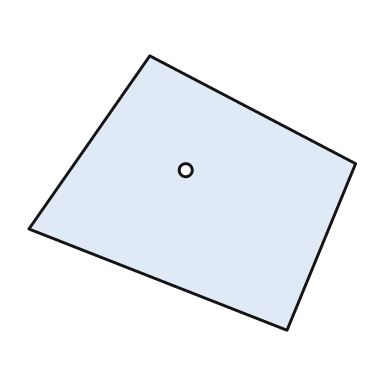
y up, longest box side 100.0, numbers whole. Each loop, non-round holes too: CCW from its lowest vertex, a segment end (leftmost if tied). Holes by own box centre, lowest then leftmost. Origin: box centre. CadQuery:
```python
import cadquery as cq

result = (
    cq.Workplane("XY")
    .moveTo(29.0, -42.0)
    .lineTo(50.0, 9.0)
    .lineTo(-13.0, 42.0)
    .lineTo(-50.0, -11.0)
    .close()
    .moveTo(-2.0, 7.0)
    .circle(2.0)
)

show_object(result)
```